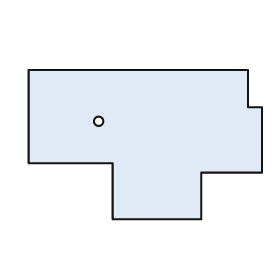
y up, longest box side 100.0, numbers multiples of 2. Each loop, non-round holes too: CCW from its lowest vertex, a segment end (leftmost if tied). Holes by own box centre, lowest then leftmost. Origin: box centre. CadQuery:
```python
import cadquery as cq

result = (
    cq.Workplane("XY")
    .moveTo(-14.0, -32.0)
    .lineTo(24.0, -32.0)
    .lineTo(24.0, -12.0)
    .lineTo(50.0, -12.0)
    .lineTo(50.0, 16.0)
    .lineTo(44.0, 16.0)
    .lineTo(44.0, 32.0)
    .lineTo(-50.0, 32.0)
    .lineTo(-50.0, -8.0)
    .lineTo(-14.0, -8.0)
    .close()
    .moveTo(-20.0, 10.0)
    .circle(2.0)
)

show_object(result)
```